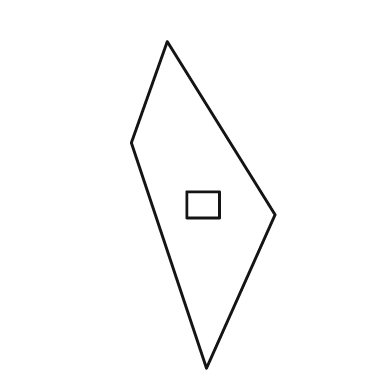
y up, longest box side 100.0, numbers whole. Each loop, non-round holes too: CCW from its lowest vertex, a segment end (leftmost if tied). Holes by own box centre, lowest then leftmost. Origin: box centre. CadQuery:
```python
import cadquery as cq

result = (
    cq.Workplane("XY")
    .moveTo(1.0, -50.0)
    .lineTo(22.0, -3.0)
    .lineTo(-11.0, 50.0)
    .lineTo(-22.0, 19.0)
    .close()
    .moveTo(-5.0, -4.0)
    .lineTo(5.0, -4.0)
    .lineTo(5.0, 4.0)
    .lineTo(-5.0, 4.0)
    .close()
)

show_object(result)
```